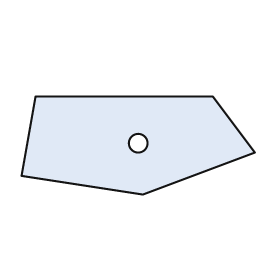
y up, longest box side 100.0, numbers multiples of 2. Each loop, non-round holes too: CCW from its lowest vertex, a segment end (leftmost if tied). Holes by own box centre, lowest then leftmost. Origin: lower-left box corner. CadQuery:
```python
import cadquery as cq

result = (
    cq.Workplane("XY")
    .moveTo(52.0, 0.0)
    .lineTo(100.0, 18.0)
    .lineTo(82.0, 42.0)
    .lineTo(6.0, 42.0)
    .lineTo(0.0, 8.0)
    .close()
    .moveTo(50.0, 22.0)
    .circle(4.0)
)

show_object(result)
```